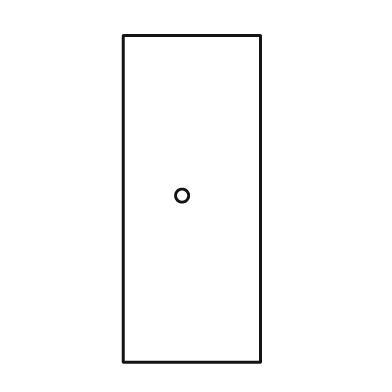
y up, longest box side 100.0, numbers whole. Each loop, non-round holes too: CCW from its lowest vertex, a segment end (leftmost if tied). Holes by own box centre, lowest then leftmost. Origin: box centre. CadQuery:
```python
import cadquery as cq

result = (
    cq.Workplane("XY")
    .moveTo(-21.0, -50.0)
    .lineTo(21.0, -50.0)
    .lineTo(21.0, 50.0)
    .lineTo(-21.0, 50.0)
    .close()
    .moveTo(-3.0, 1.0)
    .circle(2.0)
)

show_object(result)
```